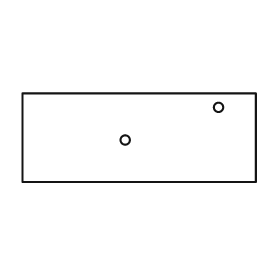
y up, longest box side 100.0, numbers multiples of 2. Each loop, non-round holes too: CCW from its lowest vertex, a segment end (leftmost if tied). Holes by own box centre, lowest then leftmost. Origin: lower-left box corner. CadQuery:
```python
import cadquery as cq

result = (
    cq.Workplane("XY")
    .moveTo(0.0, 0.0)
    .lineTo(100.0, 0.0)
    .lineTo(100.0, 38.0)
    .lineTo(0.0, 38.0)
    .close()
    .moveTo(44.0, 18.0)
    .circle(2.0)
    .moveTo(84.0, 32.0)
    .circle(2.0)
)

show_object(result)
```